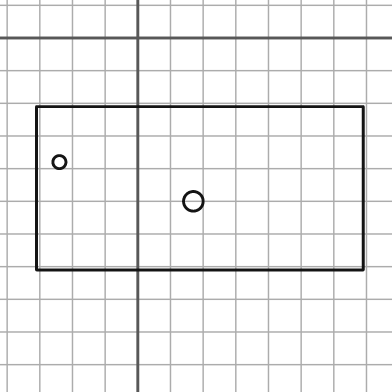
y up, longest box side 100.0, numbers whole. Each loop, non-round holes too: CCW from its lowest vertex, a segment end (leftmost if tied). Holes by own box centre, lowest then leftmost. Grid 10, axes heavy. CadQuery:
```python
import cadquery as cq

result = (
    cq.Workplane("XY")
    .moveTo(-31.0, -71.0)
    .lineTo(69.0, -71.0)
    .lineTo(69.0, -21.0)
    .lineTo(-31.0, -21.0)
    .close()
    .moveTo(17.0, -50.0)
    .circle(3.0)
    .moveTo(-24.0, -38.0)
    .circle(2.0)
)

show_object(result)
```